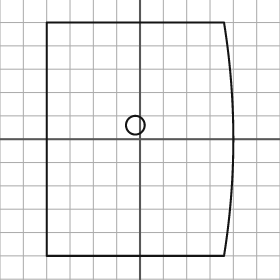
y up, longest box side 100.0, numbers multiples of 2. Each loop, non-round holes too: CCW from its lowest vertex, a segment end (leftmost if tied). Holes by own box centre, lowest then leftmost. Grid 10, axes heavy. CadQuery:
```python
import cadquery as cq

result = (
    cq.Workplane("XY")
    .moveTo(-40.0, -50.0)
    .lineTo(36.0, -50.0)
    .threePointArc((40.0, 0.0), (36.0, 50.0))
    .lineTo(-40.0, 50.0)
    .close()
    .moveTo(-2.0, 6.0)
    .circle(4.0)
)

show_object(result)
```